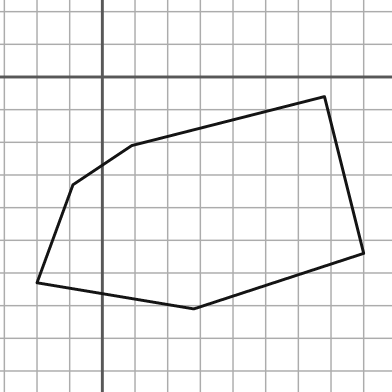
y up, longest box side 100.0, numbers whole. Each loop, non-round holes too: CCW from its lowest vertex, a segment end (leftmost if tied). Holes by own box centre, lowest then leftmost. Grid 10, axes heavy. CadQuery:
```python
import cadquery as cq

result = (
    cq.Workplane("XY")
    .moveTo(28.0, -71.0)
    .lineTo(80.0, -54.0)
    .lineTo(68.0, -6.0)
    .lineTo(9.0, -21.0)
    .lineTo(-9.0, -33.0)
    .lineTo(-20.0, -63.0)
    .close()
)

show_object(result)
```